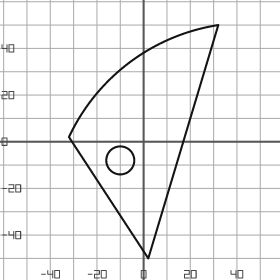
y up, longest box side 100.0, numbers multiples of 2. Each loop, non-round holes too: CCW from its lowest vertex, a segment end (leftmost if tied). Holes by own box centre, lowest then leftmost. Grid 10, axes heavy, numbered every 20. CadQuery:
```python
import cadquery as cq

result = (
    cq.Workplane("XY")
    .moveTo(2.0, -50.0)
    .lineTo(32.0, 50.0)
    .threePointArc((-6.0, 34.0), (-32.0, 2.0))
    .close()
    .moveTo(-10.0, -8.0)
    .circle(6.0)
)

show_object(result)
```